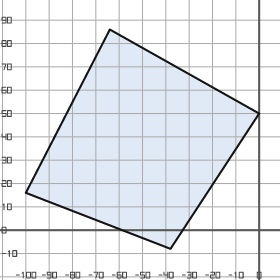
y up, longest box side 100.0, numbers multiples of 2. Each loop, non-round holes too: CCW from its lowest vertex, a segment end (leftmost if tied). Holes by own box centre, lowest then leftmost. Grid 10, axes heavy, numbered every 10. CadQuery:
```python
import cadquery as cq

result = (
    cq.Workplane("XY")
    .moveTo(-38.0, -8.0)
    .lineTo(0.0, 50.0)
    .lineTo(-64.0, 86.0)
    .lineTo(-100.0, 16.0)
    .close()
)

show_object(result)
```